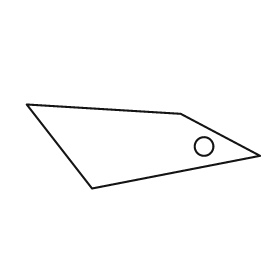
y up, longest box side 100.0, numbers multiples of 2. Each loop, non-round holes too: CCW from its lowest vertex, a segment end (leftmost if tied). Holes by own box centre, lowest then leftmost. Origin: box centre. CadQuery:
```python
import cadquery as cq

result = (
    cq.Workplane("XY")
    .moveTo(-22.0, -18.0)
    .lineTo(50.0, -4.0)
    .lineTo(16.0, 14.0)
    .lineTo(-50.0, 18.0)
    .close()
    .moveTo(26.0, 0.0)
    .circle(4.0)
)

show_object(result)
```